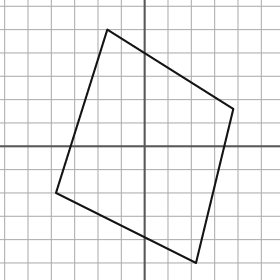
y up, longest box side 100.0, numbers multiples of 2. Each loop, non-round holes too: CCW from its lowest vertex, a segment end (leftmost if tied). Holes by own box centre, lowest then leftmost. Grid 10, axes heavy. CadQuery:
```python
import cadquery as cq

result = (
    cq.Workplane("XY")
    .moveTo(22.0, -50.0)
    .lineTo(38.0, 16.0)
    .lineTo(-16.0, 50.0)
    .lineTo(-38.0, -20.0)
    .close()
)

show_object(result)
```